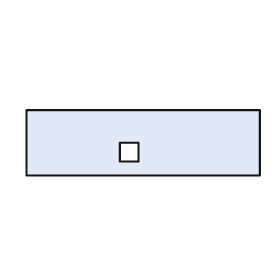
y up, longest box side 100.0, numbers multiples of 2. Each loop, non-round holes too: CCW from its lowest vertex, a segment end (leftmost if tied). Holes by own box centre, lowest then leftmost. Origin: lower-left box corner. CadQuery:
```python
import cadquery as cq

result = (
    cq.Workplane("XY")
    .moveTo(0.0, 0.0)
    .lineTo(100.0, 0.0)
    .lineTo(100.0, 28.0)
    .lineTo(0.0, 28.0)
    .close()
    .moveTo(40.0, 6.0)
    .lineTo(48.0, 6.0)
    .lineTo(48.0, 14.0)
    .lineTo(40.0, 14.0)
    .close()
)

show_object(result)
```